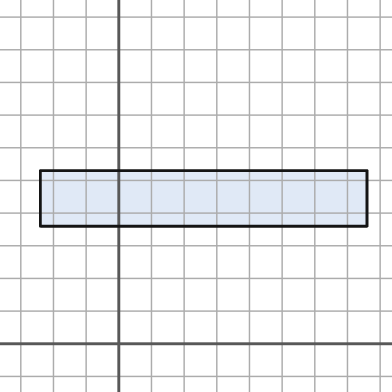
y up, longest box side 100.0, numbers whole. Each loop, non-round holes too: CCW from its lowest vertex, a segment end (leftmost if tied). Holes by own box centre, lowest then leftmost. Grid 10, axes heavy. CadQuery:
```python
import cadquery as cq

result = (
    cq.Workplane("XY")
    .moveTo(-24.0, 36.0)
    .lineTo(76.0, 36.0)
    .lineTo(76.0, 53.0)
    .lineTo(-24.0, 53.0)
    .close()
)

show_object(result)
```